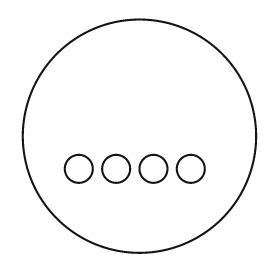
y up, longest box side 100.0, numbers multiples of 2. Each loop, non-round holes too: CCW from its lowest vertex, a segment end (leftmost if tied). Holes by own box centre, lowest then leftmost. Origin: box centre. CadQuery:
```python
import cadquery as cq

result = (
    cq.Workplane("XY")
    .moveTo(0.0, 0.0)
    .circle(50.0)
    .moveTo(-26.0, -14.0)
    .circle(6.0)
    .moveTo(-10.0, -14.0)
    .circle(6.0)
    .moveTo(6.0, -14.0)
    .circle(6.0)
    .moveTo(22.0, -14.0)
    .circle(6.0)
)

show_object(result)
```